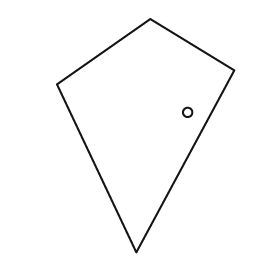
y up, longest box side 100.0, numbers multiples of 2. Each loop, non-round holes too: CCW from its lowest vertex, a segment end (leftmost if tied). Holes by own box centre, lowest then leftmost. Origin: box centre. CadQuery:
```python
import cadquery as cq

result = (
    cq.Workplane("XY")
    .moveTo(-4.0, -50.0)
    .lineTo(38.0, 28.0)
    .lineTo(2.0, 50.0)
    .lineTo(-38.0, 22.0)
    .close()
    .moveTo(18.0, 10.0)
    .circle(2.0)
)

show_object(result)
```